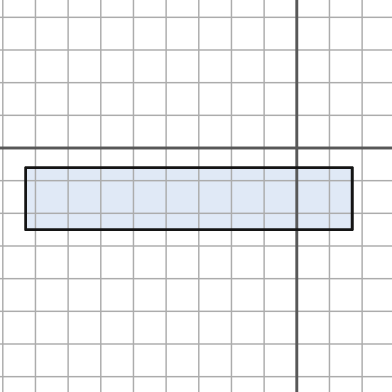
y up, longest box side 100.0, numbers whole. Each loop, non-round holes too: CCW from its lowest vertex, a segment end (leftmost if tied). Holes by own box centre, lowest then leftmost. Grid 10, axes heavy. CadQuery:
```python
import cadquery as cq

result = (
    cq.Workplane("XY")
    .moveTo(-83.0, -25.0)
    .lineTo(17.0, -25.0)
    .lineTo(17.0, -6.0)
    .lineTo(-83.0, -6.0)
    .close()
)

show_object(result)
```